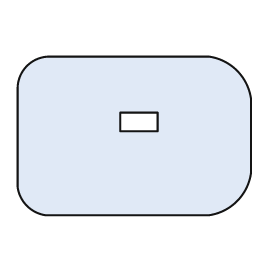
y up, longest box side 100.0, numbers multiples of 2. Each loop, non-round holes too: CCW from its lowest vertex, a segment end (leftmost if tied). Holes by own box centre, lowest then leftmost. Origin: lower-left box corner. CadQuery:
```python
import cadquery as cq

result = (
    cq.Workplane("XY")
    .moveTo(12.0, 0.0)
    .lineTo(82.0, 0.0)
    .threePointArc((94.0, 6.0), (100.0, 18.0))
    .lineTo(100.0, 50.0)
    .threePointArc((94.0, 62.0), (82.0, 68.0))
    .lineTo(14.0, 68.0)
    .threePointArc((4.0, 64.0), (0.0, 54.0))
    .lineTo(0.0, 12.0)
    .threePointArc((4.0, 4.0), (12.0, 0.0))
    .close()
    .moveTo(44.0, 36.0)
    .lineTo(60.0, 36.0)
    .lineTo(60.0, 44.0)
    .lineTo(44.0, 44.0)
    .close()
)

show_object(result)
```